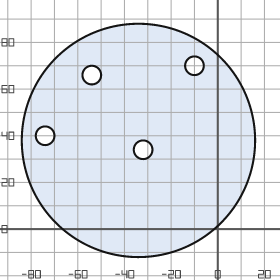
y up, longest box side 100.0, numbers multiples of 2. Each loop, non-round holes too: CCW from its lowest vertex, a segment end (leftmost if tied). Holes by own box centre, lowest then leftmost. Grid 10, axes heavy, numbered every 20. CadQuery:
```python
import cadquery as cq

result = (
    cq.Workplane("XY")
    .moveTo(-34.0, 38.0)
    .circle(50.0)
    .moveTo(-32.0, 34.0)
    .circle(4.0)
    .moveTo(-74.0, 40.0)
    .circle(4.0)
    .moveTo(-54.0, 66.0)
    .circle(4.0)
    .moveTo(-10.0, 70.0)
    .circle(4.0)
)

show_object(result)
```